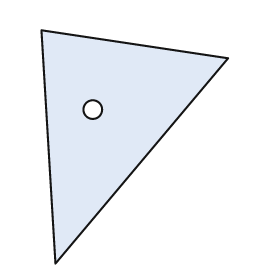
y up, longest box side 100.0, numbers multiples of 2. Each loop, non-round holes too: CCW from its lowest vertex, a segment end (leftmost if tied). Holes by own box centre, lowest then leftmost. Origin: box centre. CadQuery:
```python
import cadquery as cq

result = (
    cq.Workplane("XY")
    .moveTo(-34.0, -50.0)
    .lineTo(40.0, 38.0)
    .lineTo(-40.0, 50.0)
    .close()
    .moveTo(-18.0, 16.0)
    .circle(4.0)
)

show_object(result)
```